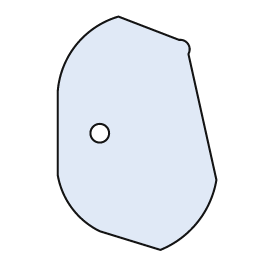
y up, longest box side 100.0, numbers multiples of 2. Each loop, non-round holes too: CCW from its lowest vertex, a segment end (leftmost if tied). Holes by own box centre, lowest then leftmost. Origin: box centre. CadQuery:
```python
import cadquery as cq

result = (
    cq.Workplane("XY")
    .moveTo(10.0, -50.0)
    .threePointArc((26.0, -38.0), (34.0, -20.0))
    .lineTo(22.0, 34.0)
    .threePointArc((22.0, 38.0), (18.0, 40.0))
    .lineTo(-8.0, 50.0)
    .threePointArc((-26.0, 38.0), (-34.0, 18.0))
    .lineTo(-34.0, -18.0)
    .threePointArc((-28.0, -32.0), (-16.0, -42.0))
    .close()
    .moveTo(-16.0, 0.0)
    .circle(4.0)
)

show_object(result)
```